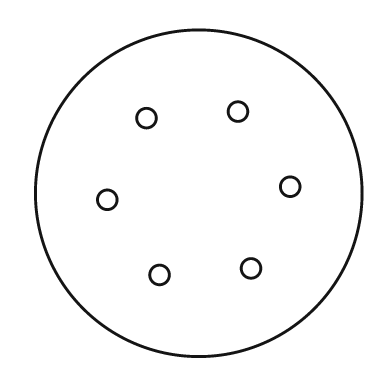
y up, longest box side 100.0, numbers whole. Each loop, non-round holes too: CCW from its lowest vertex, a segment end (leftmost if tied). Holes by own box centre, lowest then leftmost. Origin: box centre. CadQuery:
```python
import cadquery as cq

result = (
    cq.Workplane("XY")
    .moveTo(0.0, 0.0)
    .circle(50.0)
    .moveTo(-12.0, -25.0)
    .circle(3.0)
    .moveTo(16.0, -23.0)
    .circle(3.0)
    .moveTo(-28.0, -2.0)
    .circle(3.0)
    .moveTo(28.0, 2.0)
    .circle(3.0)
    .moveTo(-16.0, 23.0)
    .circle(3.0)
    .moveTo(12.0, 25.0)
    .circle(3.0)
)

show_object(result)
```